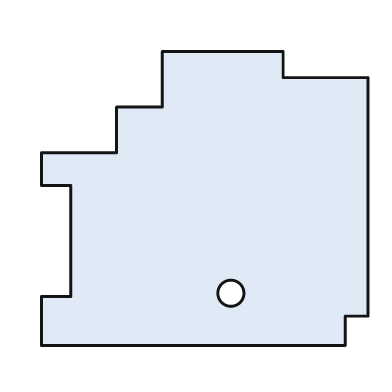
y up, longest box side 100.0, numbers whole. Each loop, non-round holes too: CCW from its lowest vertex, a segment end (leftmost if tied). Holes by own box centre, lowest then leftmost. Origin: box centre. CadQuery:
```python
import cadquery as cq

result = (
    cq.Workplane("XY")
    .moveTo(-50.0, -45.0)
    .lineTo(43.0, -45.0)
    .lineTo(43.0, -36.0)
    .lineTo(50.0, -36.0)
    .lineTo(50.0, 37.0)
    .lineTo(24.0, 37.0)
    .lineTo(24.0, 45.0)
    .lineTo(-13.0, 45.0)
    .lineTo(-13.0, 28.0)
    .lineTo(-27.0, 28.0)
    .lineTo(-27.0, 14.0)
    .lineTo(-50.0, 14.0)
    .lineTo(-50.0, 4.0)
    .lineTo(-41.0, 4.0)
    .lineTo(-41.0, -30.0)
    .lineTo(-50.0, -30.0)
    .close()
    .moveTo(8.0, -29.0)
    .circle(4.0)
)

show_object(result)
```